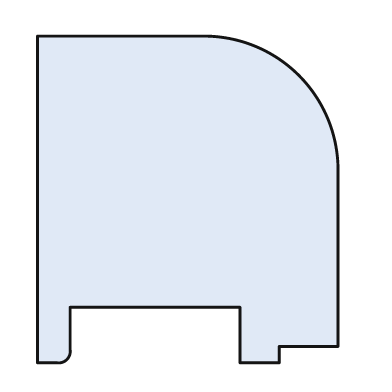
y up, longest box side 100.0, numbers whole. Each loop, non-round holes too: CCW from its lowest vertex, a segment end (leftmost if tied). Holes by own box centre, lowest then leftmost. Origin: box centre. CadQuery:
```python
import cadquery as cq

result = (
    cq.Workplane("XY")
    .moveTo(-46.0, -50.0)
    .lineTo(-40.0, -50.0)
    .threePointArc((-37.0, -49.0), (-36.0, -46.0))
    .lineTo(-36.0, -33.0)
    .lineTo(16.0, -33.0)
    .lineTo(16.0, -50.0)
    .lineTo(28.0, -50.0)
    .lineTo(28.0, -45.0)
    .lineTo(46.0, -45.0)
    .lineTo(46.0, 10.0)
    .threePointArc((34.0, 38.0), (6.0, 50.0))
    .lineTo(-46.0, 50.0)
    .close()
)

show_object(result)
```